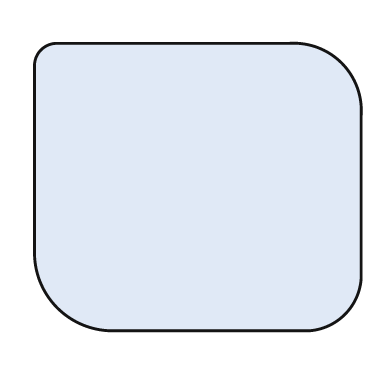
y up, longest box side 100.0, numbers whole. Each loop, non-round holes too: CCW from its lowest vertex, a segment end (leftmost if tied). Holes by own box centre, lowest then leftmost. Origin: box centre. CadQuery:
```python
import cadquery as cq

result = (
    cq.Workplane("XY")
    .moveTo(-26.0, -44.0)
    .lineTo(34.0, -44.0)
    .threePointArc((45.0, -39.0), (50.0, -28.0))
    .lineTo(50.0, 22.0)
    .threePointArc((44.0, 38.0), (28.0, 44.0))
    .lineTo(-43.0, 44.0)
    .threePointArc((-48.0, 42.0), (-50.0, 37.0))
    .lineTo(-50.0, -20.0)
    .threePointArc((-43.0, -37.0), (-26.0, -44.0))
    .close()
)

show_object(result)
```